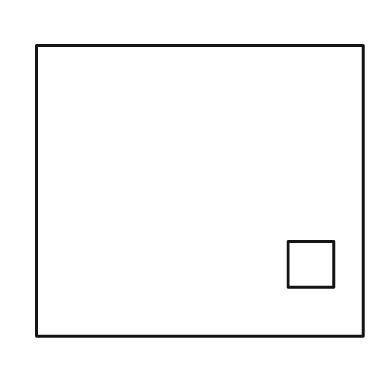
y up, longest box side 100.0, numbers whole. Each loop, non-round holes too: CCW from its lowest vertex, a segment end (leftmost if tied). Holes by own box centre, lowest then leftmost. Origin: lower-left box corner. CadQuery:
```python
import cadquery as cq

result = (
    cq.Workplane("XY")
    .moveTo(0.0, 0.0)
    .lineTo(100.0, 0.0)
    .lineTo(100.0, 89.0)
    .lineTo(0.0, 89.0)
    .close()
    .moveTo(77.0, 15.0)
    .lineTo(91.0, 15.0)
    .lineTo(91.0, 29.0)
    .lineTo(77.0, 29.0)
    .close()
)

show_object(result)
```